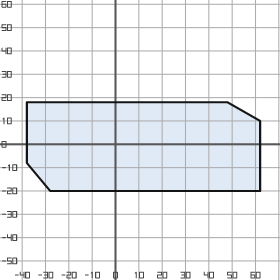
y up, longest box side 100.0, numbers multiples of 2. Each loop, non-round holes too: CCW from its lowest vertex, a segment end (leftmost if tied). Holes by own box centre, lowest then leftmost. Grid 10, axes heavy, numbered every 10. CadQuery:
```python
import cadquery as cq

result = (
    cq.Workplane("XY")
    .moveTo(-28.0, -20.0)
    .lineTo(62.0, -20.0)
    .lineTo(62.0, 10.0)
    .lineTo(48.0, 18.0)
    .lineTo(-38.0, 18.0)
    .lineTo(-38.0, -8.0)
    .close()
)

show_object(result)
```